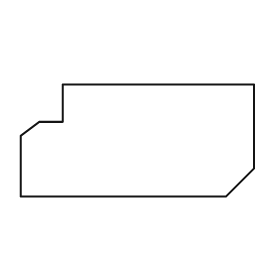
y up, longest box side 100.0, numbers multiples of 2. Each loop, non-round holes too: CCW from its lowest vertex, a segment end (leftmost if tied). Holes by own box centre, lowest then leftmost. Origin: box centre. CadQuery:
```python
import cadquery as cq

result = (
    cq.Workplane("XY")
    .moveTo(-50.0, -24.0)
    .lineTo(38.0, -24.0)
    .lineTo(50.0, -12.0)
    .lineTo(50.0, 24.0)
    .lineTo(-32.0, 24.0)
    .lineTo(-32.0, 8.0)
    .lineTo(-42.0, 8.0)
    .lineTo(-50.0, 2.0)
    .close()
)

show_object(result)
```